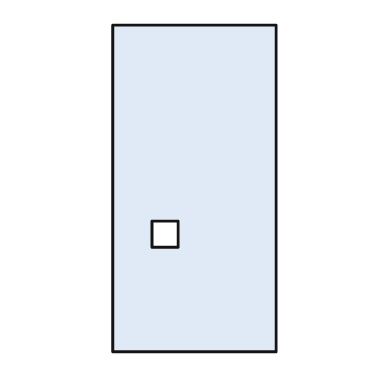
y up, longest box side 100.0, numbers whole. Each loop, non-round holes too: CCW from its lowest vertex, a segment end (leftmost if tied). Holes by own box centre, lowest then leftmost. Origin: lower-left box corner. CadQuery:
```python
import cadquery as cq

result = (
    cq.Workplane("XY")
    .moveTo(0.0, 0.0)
    .lineTo(50.0, 0.0)
    .lineTo(50.0, 100.0)
    .lineTo(0.0, 100.0)
    .close()
    .moveTo(12.0, 32.0)
    .lineTo(20.0, 32.0)
    .lineTo(20.0, 40.0)
    .lineTo(12.0, 40.0)
    .close()
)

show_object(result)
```